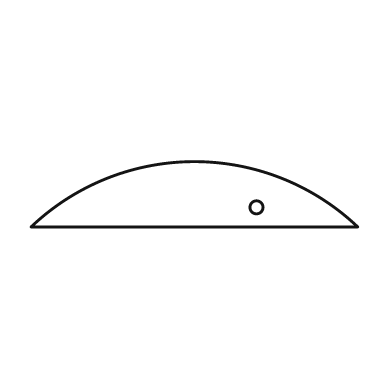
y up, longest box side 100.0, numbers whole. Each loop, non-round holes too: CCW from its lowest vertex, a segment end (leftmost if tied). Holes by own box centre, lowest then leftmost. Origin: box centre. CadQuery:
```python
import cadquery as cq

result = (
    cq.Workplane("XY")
    .moveTo(-50.0, -10.0)
    .lineTo(50.0, -10.0)
    .threePointArc((0.0, 10.0), (-50.0, -10.0))
    .close()
    .moveTo(19.0, -4.0)
    .circle(2.0)
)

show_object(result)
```